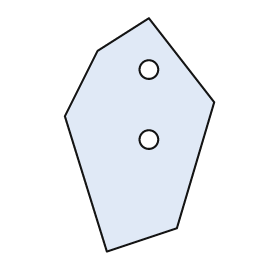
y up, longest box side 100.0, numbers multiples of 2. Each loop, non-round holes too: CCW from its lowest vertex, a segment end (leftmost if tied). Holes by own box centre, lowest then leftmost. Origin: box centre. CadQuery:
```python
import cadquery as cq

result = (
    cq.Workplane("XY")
    .moveTo(-14.0, -50.0)
    .lineTo(16.0, -40.0)
    .lineTo(32.0, 14.0)
    .lineTo(4.0, 50.0)
    .lineTo(-18.0, 36.0)
    .lineTo(-32.0, 8.0)
    .close()
    .moveTo(4.0, -2.0)
    .circle(4.0)
    .moveTo(4.0, 28.0)
    .circle(4.0)
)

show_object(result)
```